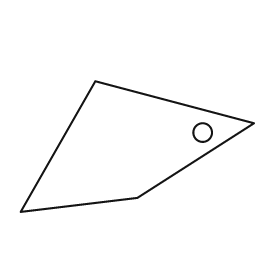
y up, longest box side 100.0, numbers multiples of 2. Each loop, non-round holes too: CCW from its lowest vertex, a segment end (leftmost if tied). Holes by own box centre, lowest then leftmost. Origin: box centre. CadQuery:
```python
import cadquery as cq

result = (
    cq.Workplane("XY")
    .moveTo(-50.0, -28.0)
    .lineTo(0.0, -22.0)
    .lineTo(50.0, 10.0)
    .lineTo(-18.0, 28.0)
    .close()
    .moveTo(28.0, 6.0)
    .circle(4.0)
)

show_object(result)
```